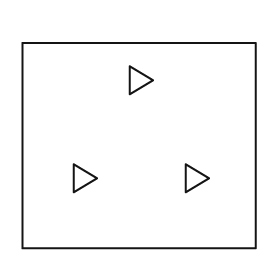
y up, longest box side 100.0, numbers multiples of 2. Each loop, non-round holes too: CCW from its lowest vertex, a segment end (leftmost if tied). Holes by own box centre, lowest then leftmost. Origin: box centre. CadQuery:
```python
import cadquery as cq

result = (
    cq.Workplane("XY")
    .moveTo(-50.0, -44.0)
    .lineTo(50.0, -44.0)
    .lineTo(50.0, 44.0)
    .lineTo(-50.0, 44.0)
    .close()
    .moveTo(-28.0, -20.0)
    .lineTo(-18.0, -14.0)
    .lineTo(-28.0, -8.0)
    .close()
    .moveTo(20.0, -20.0)
    .lineTo(30.0, -14.0)
    .lineTo(20.0, -8.0)
    .close()
    .moveTo(-4.0, 22.0)
    .lineTo(6.0, 28.0)
    .lineTo(-4.0, 34.0)
    .close()
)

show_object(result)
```